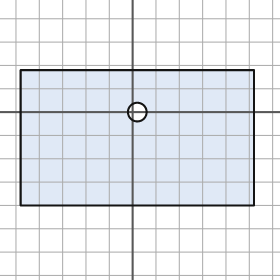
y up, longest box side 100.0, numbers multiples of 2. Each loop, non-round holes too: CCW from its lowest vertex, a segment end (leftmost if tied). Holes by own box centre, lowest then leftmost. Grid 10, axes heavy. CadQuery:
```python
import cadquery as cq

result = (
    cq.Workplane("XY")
    .moveTo(-48.0, -40.0)
    .lineTo(52.0, -40.0)
    .lineTo(52.0, 18.0)
    .lineTo(-48.0, 18.0)
    .close()
    .moveTo(2.0, 0.0)
    .circle(4.0)
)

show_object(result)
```